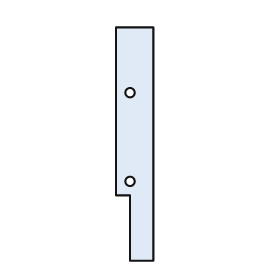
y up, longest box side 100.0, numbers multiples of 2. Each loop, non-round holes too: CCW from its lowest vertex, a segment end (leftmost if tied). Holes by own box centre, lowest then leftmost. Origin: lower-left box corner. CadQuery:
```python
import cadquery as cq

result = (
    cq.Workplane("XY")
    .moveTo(6.0, 0.0)
    .lineTo(16.0, 0.0)
    .lineTo(16.0, 100.0)
    .lineTo(0.0, 100.0)
    .lineTo(0.0, 28.0)
    .lineTo(6.0, 28.0)
    .close()
    .moveTo(6.0, 34.0)
    .circle(2.0)
    .moveTo(6.0, 72.0)
    .circle(2.0)
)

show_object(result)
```